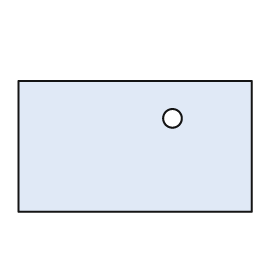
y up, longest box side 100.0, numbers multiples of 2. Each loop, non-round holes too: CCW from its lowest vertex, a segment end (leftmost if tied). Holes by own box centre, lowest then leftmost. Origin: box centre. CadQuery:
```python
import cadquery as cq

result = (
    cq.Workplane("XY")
    .moveTo(-50.0, -28.0)
    .lineTo(50.0, -28.0)
    .lineTo(50.0, 28.0)
    .lineTo(-50.0, 28.0)
    .close()
    .moveTo(16.0, 12.0)
    .circle(4.0)
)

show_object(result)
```